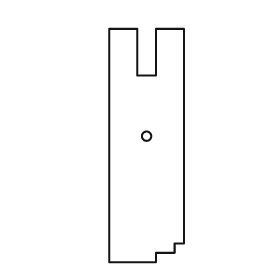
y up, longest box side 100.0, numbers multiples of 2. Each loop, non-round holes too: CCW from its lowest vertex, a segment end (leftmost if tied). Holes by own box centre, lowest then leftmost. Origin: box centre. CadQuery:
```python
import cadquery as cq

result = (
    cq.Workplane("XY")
    .moveTo(-16.0, -50.0)
    .lineTo(4.0, -50.0)
    .lineTo(4.0, -46.0)
    .lineTo(12.0, -46.0)
    .lineTo(12.0, -42.0)
    .lineTo(16.0, -42.0)
    .lineTo(16.0, 50.0)
    .lineTo(4.0, 50.0)
    .lineTo(4.0, 30.0)
    .lineTo(-4.0, 30.0)
    .lineTo(-4.0, 50.0)
    .lineTo(-16.0, 50.0)
    .close()
    .moveTo(0.0, 4.0)
    .circle(2.0)
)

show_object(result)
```